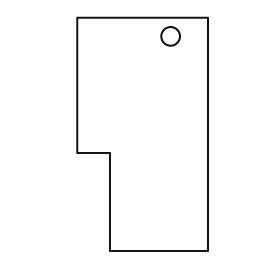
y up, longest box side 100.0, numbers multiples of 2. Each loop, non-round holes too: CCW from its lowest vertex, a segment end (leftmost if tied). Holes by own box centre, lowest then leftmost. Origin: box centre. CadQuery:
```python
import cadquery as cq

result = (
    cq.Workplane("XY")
    .moveTo(-14.0, -50.0)
    .lineTo(28.0, -50.0)
    .lineTo(28.0, 50.0)
    .lineTo(-28.0, 50.0)
    .lineTo(-28.0, -8.0)
    .lineTo(-14.0, -8.0)
    .close()
    .moveTo(12.0, 42.0)
    .circle(4.0)
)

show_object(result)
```